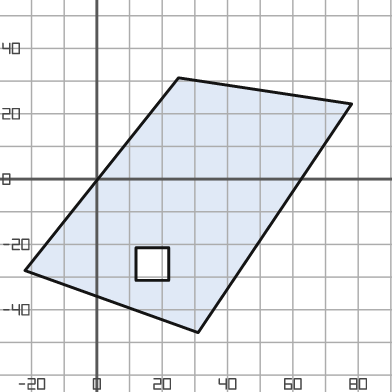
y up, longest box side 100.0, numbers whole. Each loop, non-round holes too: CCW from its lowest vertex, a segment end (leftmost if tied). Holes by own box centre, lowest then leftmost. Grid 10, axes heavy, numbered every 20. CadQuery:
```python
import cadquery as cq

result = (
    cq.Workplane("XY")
    .moveTo(31.0, -47.0)
    .lineTo(78.0, 23.0)
    .lineTo(25.0, 31.0)
    .lineTo(-22.0, -28.0)
    .close()
    .moveTo(12.0, -31.0)
    .lineTo(22.0, -31.0)
    .lineTo(22.0, -21.0)
    .lineTo(12.0, -21.0)
    .close()
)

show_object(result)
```